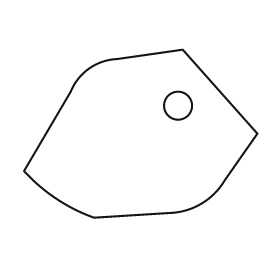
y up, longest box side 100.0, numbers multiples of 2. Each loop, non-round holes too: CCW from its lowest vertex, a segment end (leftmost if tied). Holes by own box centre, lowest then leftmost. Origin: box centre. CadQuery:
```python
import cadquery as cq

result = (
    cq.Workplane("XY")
    .moveTo(-20.0, -36.0)
    .lineTo(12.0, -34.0)
    .threePointArc((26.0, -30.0), (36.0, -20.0))
    .lineTo(50.0, 0.0)
    .lineTo(18.0, 36.0)
    .lineTo(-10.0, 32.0)
    .threePointArc((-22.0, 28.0), (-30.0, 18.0))
    .lineTo(-50.0, -16.0)
    .threePointArc((-36.0, -28.0), (-20.0, -36.0))
    .close()
    .moveTo(16.0, 12.0)
    .circle(6.0)
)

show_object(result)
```